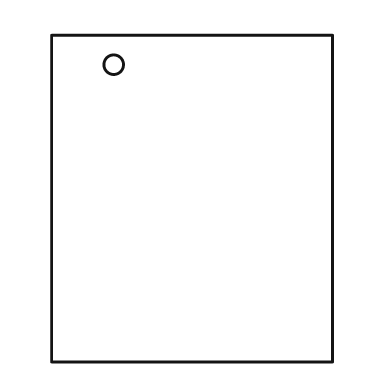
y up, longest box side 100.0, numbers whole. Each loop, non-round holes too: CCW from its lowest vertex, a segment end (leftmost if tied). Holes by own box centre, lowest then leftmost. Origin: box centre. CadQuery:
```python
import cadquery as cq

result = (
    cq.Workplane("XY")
    .moveTo(-43.0, -50.0)
    .lineTo(43.0, -50.0)
    .lineTo(43.0, 50.0)
    .lineTo(-43.0, 50.0)
    .close()
    .moveTo(-24.0, 41.0)
    .circle(3.0)
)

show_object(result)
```